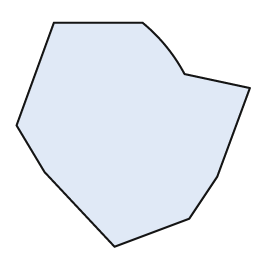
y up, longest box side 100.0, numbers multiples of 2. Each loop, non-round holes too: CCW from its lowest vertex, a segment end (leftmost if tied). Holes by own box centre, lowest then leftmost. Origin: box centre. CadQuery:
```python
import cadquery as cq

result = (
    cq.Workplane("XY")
    .moveTo(-8.0, -48.0)
    .lineTo(24.0, -36.0)
    .lineTo(36.0, -18.0)
    .lineTo(50.0, 20.0)
    .lineTo(22.0, 26.0)
    .threePointArc((14.0, 38.0), (4.0, 48.0))
    .lineTo(-34.0, 48.0)
    .lineTo(-50.0, 4.0)
    .lineTo(-38.0, -16.0)
    .close()
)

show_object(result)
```